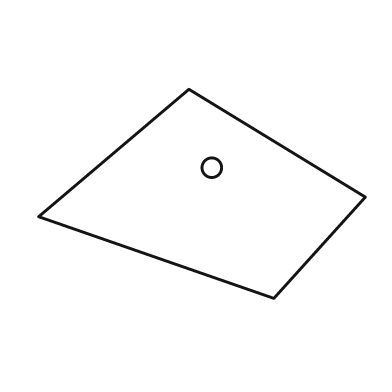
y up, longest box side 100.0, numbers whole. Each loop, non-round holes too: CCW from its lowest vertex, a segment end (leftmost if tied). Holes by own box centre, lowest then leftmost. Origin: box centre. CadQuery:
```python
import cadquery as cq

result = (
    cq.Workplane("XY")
    .moveTo(22.0, -32.0)
    .lineTo(50.0, -1.0)
    .lineTo(-4.0, 32.0)
    .lineTo(-50.0, -7.0)
    .close()
    .moveTo(3.0, 8.0)
    .circle(3.0)
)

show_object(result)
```